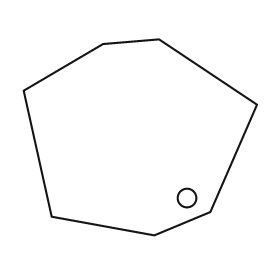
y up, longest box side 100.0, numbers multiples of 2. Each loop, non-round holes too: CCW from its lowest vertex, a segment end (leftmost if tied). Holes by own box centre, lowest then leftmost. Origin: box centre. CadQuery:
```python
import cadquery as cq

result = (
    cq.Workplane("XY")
    .moveTo(6.0, -42.0)
    .lineTo(30.0, -32.0)
    .lineTo(50.0, 14.0)
    .lineTo(8.0, 42.0)
    .lineTo(-16.0, 40.0)
    .lineTo(-50.0, 20.0)
    .lineTo(-38.0, -34.0)
    .close()
    .moveTo(20.0, -26.0)
    .circle(4.0)
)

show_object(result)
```